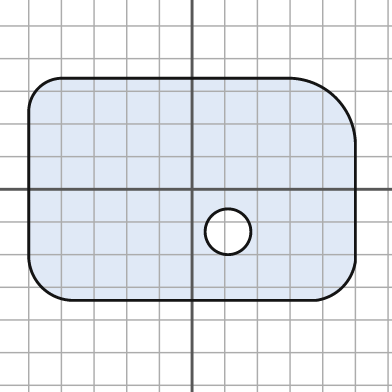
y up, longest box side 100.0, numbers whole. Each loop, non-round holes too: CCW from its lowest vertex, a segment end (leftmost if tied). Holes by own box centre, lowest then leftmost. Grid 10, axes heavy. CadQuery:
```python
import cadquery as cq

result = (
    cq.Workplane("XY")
    .moveTo(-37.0, -34.0)
    .lineTo(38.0, -34.0)
    .threePointArc((46.0, -30.0), (50.0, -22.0))
    .lineTo(50.0, 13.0)
    .threePointArc((44.0, 28.0), (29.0, 34.0))
    .lineTo(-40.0, 34.0)
    .threePointArc((-47.0, 31.0), (-50.0, 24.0))
    .lineTo(-50.0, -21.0)
    .threePointArc((-46.0, -30.0), (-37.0, -34.0))
    .close()
    .moveTo(11.0, -13.0)
    .circle(7.0)
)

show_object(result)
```